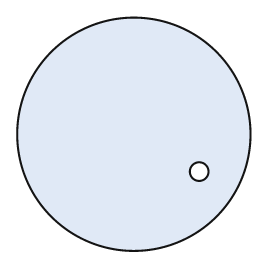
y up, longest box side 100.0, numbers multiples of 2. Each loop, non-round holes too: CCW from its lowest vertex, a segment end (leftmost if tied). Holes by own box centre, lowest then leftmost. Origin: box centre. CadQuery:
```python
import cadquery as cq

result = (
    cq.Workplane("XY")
    .moveTo(0.0, 0.0)
    .circle(50.0)
    .moveTo(28.0, -16.0)
    .circle(4.0)
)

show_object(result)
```